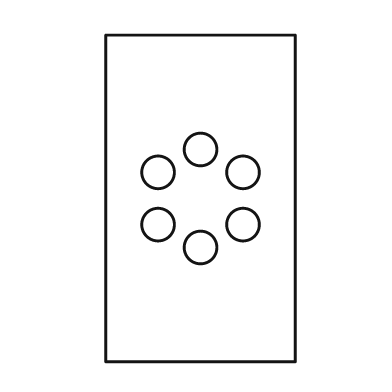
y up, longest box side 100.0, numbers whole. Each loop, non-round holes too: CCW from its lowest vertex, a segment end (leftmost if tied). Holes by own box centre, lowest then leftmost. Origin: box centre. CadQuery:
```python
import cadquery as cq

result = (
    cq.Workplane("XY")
    .moveTo(-29.0, -50.0)
    .lineTo(29.0, -50.0)
    .lineTo(29.0, 50.0)
    .lineTo(-29.0, 50.0)
    .close()
    .moveTo(0.0, -15.0)
    .circle(5.0)
    .moveTo(-13.0, -8.0)
    .circle(5.0)
    .moveTo(13.0, -8.0)
    .circle(5.0)
    .moveTo(-13.0, 8.0)
    .circle(5.0)
    .moveTo(13.0, 8.0)
    .circle(5.0)
    .moveTo(0.0, 15.0)
    .circle(5.0)
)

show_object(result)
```